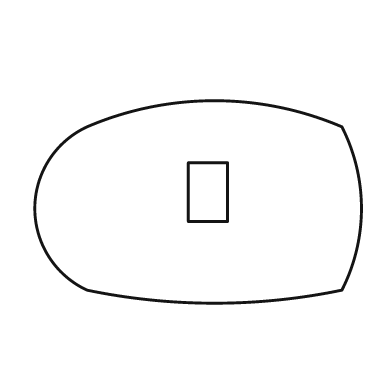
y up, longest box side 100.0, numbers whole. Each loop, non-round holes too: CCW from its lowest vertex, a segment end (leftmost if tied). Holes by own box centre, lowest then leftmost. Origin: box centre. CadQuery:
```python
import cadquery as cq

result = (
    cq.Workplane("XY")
    .moveTo(-34.0, -27.0)
    .threePointArc((5.0, -31.0), (44.0, -27.0))
    .threePointArc((50.0, -2.0), (44.0, 23.0))
    .threePointArc((5.0, 31.0), (-34.0, 23.0))
    .threePointArc((-50.0, -2.0), (-34.0, -27.0))
    .close()
    .moveTo(-3.0, -6.0)
    .lineTo(9.0, -6.0)
    .lineTo(9.0, 12.0)
    .lineTo(-3.0, 12.0)
    .close()
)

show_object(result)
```